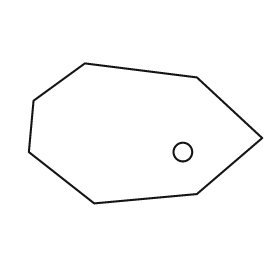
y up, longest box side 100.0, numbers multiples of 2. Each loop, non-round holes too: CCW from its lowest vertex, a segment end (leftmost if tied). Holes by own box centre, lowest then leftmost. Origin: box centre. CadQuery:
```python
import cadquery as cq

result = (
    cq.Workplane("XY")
    .moveTo(-22.0, -30.0)
    .lineTo(22.0, -26.0)
    .lineTo(50.0, -2.0)
    .lineTo(22.0, 24.0)
    .lineTo(-26.0, 30.0)
    .lineTo(-48.0, 14.0)
    .lineTo(-50.0, -8.0)
    .close()
    .moveTo(16.0, -8.0)
    .circle(4.0)
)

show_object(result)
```